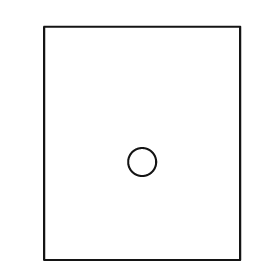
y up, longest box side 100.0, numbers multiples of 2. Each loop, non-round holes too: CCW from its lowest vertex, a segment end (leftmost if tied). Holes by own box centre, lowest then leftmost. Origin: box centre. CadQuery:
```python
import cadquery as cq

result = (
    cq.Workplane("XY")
    .moveTo(-42.0, -50.0)
    .lineTo(42.0, -50.0)
    .lineTo(42.0, 50.0)
    .lineTo(-42.0, 50.0)
    .close()
    .moveTo(0.0, -8.0)
    .circle(6.0)
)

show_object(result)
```